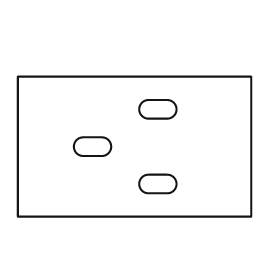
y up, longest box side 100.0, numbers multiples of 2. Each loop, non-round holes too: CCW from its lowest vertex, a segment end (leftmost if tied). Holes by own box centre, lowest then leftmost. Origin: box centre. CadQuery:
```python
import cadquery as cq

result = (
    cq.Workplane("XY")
    .moveTo(-50.0, -30.0)
    .lineTo(50.0, -30.0)
    .lineTo(50.0, 30.0)
    .lineTo(-50.0, 30.0)
    .close()
    .moveTo(6.0, -20.0)
    .lineTo(14.0, -20.0)
    .threePointArc((18.0, -16.0), (14.0, -12.0))
    .lineTo(6.0, -12.0)
    .threePointArc((2.0, -16.0), (6.0, -20.0))
    .close()
    .moveTo(-22.0, -4.0)
    .lineTo(-14.0, -4.0)
    .threePointArc((-10.0, 0.0), (-14.0, 4.0))
    .lineTo(-22.0, 4.0)
    .threePointArc((-26.0, 0.0), (-22.0, -4.0))
    .close()
    .moveTo(6.0, 12.0)
    .lineTo(14.0, 12.0)
    .threePointArc((18.0, 16.0), (14.0, 20.0))
    .lineTo(6.0, 20.0)
    .threePointArc((2.0, 16.0), (6.0, 12.0))
    .close()
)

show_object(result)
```